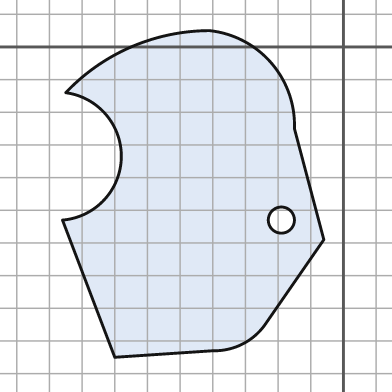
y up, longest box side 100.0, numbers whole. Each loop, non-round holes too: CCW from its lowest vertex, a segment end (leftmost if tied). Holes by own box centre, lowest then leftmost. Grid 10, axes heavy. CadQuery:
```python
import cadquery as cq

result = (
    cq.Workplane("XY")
    .moveTo(-70.0, -95.0)
    .lineTo(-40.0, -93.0)
    .threePointArc((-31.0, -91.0), (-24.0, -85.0))
    .lineTo(-6.0, -59.0)
    .lineTo(-15.0, -25.0)
    .threePointArc((-22.0, -5.0), (-41.0, 5.0))
    .threePointArc((-65.0, 0.0), (-85.0, -14.0))
    .threePointArc((-68.0, -34.0), (-86.0, -53.0))
    .close()
    .moveTo(-19.0, -53.0)
    .circle(4.0)
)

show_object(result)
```